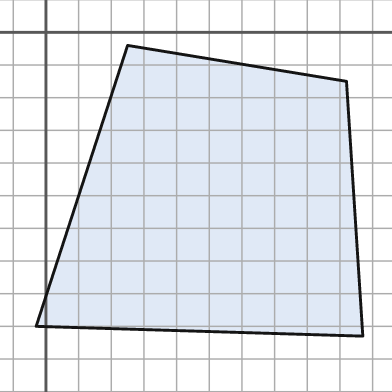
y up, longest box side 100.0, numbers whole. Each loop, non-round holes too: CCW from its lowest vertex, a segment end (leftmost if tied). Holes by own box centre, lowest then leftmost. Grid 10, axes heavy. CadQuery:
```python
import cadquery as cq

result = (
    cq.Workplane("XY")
    .moveTo(97.0, -93.0)
    .lineTo(92.0, -15.0)
    .lineTo(25.0, -4.0)
    .lineTo(-3.0, -90.0)
    .close()
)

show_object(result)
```